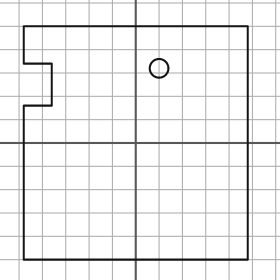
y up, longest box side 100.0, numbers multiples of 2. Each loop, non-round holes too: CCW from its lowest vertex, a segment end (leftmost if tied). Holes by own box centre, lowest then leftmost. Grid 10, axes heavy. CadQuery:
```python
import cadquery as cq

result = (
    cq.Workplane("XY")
    .moveTo(-48.0, -50.0)
    .lineTo(48.0, -50.0)
    .lineTo(48.0, 50.0)
    .lineTo(-48.0, 50.0)
    .lineTo(-48.0, 34.0)
    .lineTo(-36.0, 34.0)
    .lineTo(-36.0, 16.0)
    .lineTo(-48.0, 16.0)
    .close()
    .moveTo(10.0, 32.0)
    .circle(4.0)
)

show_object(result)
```